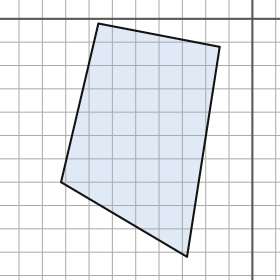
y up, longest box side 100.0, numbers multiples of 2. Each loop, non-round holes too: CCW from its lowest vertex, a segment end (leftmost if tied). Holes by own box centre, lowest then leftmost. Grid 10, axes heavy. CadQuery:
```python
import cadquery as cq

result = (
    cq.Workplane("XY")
    .moveTo(-28.0, -102.0)
    .lineTo(-14.0, -12.0)
    .lineTo(-66.0, -2.0)
    .lineTo(-82.0, -70.0)
    .close()
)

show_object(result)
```